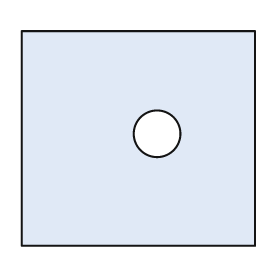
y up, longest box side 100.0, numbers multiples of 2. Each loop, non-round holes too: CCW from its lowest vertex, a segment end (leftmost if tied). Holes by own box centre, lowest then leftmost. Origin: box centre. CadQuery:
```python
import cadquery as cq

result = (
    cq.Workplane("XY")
    .moveTo(-50.0, -46.0)
    .lineTo(50.0, -46.0)
    .lineTo(50.0, 46.0)
    .lineTo(-50.0, 46.0)
    .close()
    .moveTo(8.0, 2.0)
    .circle(10.0)
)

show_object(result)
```